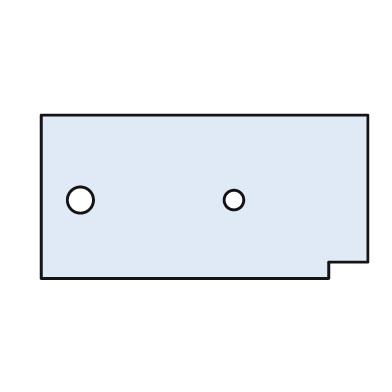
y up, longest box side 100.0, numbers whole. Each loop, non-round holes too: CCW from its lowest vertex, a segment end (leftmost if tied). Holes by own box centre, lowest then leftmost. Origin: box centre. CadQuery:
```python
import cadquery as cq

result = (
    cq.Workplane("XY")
    .moveTo(-50.0, -25.0)
    .lineTo(38.0, -25.0)
    .lineTo(38.0, -20.0)
    .lineTo(50.0, -20.0)
    .lineTo(50.0, 25.0)
    .lineTo(-50.0, 25.0)
    .close()
    .moveTo(-38.0, -1.0)
    .circle(4.0)
    .moveTo(9.0, -1.0)
    .circle(3.0)
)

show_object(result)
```